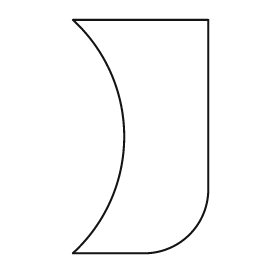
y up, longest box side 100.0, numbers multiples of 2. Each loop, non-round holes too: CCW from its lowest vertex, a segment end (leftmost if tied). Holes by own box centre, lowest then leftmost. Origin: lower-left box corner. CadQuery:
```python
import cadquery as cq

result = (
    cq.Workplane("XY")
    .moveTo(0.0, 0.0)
    .lineTo(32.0, 0.0)
    .threePointArc((50.0, 8.0), (58.0, 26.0))
    .lineTo(58.0, 100.0)
    .lineTo(0.0, 100.0)
    .threePointArc((22.0, 50.0), (0.0, 0.0))
    .close()
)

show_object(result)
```